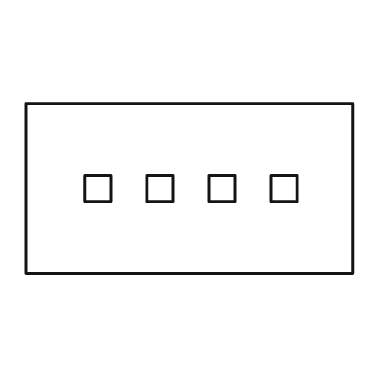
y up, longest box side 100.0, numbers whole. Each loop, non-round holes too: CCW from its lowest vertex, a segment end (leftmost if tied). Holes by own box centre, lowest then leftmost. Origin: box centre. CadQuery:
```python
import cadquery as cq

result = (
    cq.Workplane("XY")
    .moveTo(-50.0, -26.0)
    .lineTo(50.0, -26.0)
    .lineTo(50.0, 26.0)
    .lineTo(-50.0, 26.0)
    .close()
    .moveTo(-32.0, -4.0)
    .lineTo(-24.0, -4.0)
    .lineTo(-24.0, 4.0)
    .lineTo(-32.0, 4.0)
    .close()
    .moveTo(-13.0, -4.0)
    .lineTo(-5.0, -4.0)
    .lineTo(-5.0, 4.0)
    .lineTo(-13.0, 4.0)
    .close()
    .moveTo(6.0, -4.0)
    .lineTo(14.0, -4.0)
    .lineTo(14.0, 4.0)
    .lineTo(6.0, 4.0)
    .close()
    .moveTo(25.0, -4.0)
    .lineTo(33.0, -4.0)
    .lineTo(33.0, 4.0)
    .lineTo(25.0, 4.0)
    .close()
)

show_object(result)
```